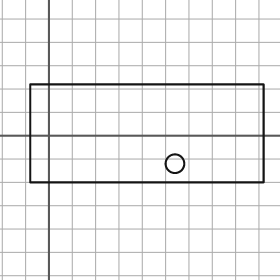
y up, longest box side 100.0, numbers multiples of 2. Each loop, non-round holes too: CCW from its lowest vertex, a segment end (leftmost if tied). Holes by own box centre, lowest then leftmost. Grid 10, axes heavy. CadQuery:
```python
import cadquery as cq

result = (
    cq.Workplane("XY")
    .moveTo(-8.0, -20.0)
    .lineTo(92.0, -20.0)
    .lineTo(92.0, 22.0)
    .lineTo(-8.0, 22.0)
    .close()
    .moveTo(54.0, -12.0)
    .circle(4.0)
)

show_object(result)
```